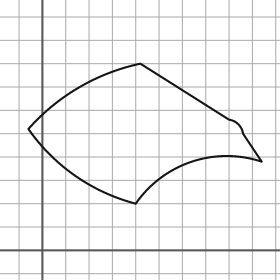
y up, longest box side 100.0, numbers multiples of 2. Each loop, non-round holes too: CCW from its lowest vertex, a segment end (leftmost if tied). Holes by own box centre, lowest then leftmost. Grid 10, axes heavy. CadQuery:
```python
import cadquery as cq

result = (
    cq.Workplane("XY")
    .moveTo(40.0, 20.0)
    .threePointArc((64.0, 38.0), (94.0, 38.0))
    .lineTo(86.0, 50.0)
    .threePointArc((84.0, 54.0), (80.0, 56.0))
    .lineTo(42.0, 80.0)
    .threePointArc((16.0, 70.0), (-6.0, 52.0))
    .threePointArc((14.0, 32.0), (40.0, 20.0))
    .close()
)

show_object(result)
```